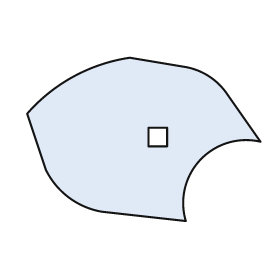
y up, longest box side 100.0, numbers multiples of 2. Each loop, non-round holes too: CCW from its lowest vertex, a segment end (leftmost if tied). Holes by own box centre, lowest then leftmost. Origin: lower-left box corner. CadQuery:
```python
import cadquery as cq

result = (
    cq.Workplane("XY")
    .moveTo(68.0, 0.0)
    .threePointArc((74.0, 26.0), (100.0, 34.0))
    .lineTo(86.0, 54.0)
    .threePointArc((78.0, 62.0), (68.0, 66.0))
    .lineTo(44.0, 70.0)
    .threePointArc((20.0, 62.0), (0.0, 46.0))
    .lineTo(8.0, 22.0)
    .threePointArc((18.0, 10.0), (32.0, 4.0))
    .close()
    .moveTo(52.0, 32.0)
    .lineTo(60.0, 32.0)
    .lineTo(60.0, 40.0)
    .lineTo(52.0, 40.0)
    .close()
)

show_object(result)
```